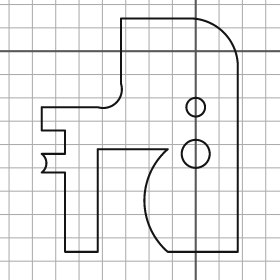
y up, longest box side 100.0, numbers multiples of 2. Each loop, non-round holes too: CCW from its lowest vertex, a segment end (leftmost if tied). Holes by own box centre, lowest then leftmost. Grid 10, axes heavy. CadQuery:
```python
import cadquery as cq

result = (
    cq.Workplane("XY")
    .moveTo(-56.0, -86.0)
    .lineTo(-42.0, -86.0)
    .lineTo(-42.0, -42.0)
    .lineTo(-12.0, -42.0)
    .threePointArc((-22.0, -64.0), (-12.0, -86.0))
    .lineTo(18.0, -86.0)
    .lineTo(18.0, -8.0)
    .threePointArc((12.0, 8.0), (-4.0, 14.0))
    .lineTo(-32.0, 14.0)
    .lineTo(-32.0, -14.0)
    .threePointArc((-34.0, -22.0), (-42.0, -24.0))
    .lineTo(-66.0, -24.0)
    .lineTo(-66.0, -34.0)
    .lineTo(-56.0, -34.0)
    .lineTo(-56.0, -44.0)
    .lineTo(-66.0, -44.0)
    .threePointArc((-64.0, -48.0), (-66.0, -52.0))
    .lineTo(-56.0, -52.0)
    .close()
    .moveTo(0.0, -44.0)
    .circle(6.0)
    .moveTo(0.0, -24.0)
    .circle(4.0)
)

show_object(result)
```